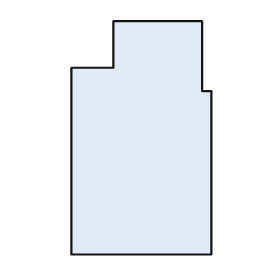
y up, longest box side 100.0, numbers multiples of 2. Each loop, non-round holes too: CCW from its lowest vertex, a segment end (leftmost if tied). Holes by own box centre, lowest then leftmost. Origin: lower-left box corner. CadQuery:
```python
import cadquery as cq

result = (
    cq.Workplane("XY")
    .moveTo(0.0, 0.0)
    .lineTo(60.0, 0.0)
    .lineTo(60.0, 70.0)
    .lineTo(56.0, 70.0)
    .lineTo(56.0, 100.0)
    .lineTo(18.0, 100.0)
    .lineTo(18.0, 80.0)
    .lineTo(0.0, 80.0)
    .close()
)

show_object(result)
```